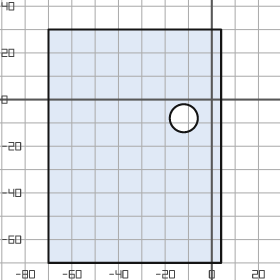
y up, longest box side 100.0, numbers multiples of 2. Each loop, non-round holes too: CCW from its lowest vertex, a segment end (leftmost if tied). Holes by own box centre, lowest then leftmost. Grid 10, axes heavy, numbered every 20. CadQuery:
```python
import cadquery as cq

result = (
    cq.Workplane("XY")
    .moveTo(-70.0, -70.0)
    .lineTo(4.0, -70.0)
    .lineTo(4.0, 30.0)
    .lineTo(-70.0, 30.0)
    .close()
    .moveTo(-12.0, -8.0)
    .circle(6.0)
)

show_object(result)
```